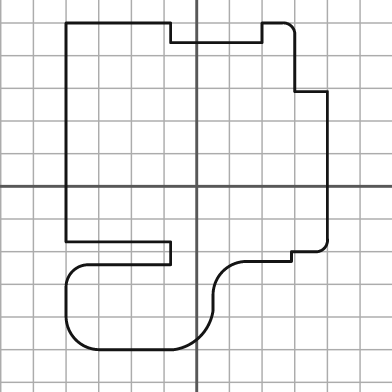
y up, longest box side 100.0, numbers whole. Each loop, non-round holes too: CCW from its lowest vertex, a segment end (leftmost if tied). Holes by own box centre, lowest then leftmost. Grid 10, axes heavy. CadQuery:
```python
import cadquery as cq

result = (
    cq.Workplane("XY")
    .moveTo(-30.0, -50.0)
    .lineTo(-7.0, -50.0)
    .threePointArc((1.0, -46.0), (5.0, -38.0))
    .lineTo(5.0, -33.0)
    .threePointArc((8.0, -26.0), (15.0, -23.0))
    .lineTo(29.0, -23.0)
    .lineTo(29.0, -20.0)
    .lineTo(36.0, -20.0)
    .threePointArc((39.0, -19.0), (40.0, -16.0))
    .lineTo(40.0, 29.0)
    .lineTo(30.0, 29.0)
    .lineTo(30.0, 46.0)
    .threePointArc((29.0, 49.0), (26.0, 50.0))
    .lineTo(20.0, 50.0)
    .lineTo(20.0, 44.0)
    .lineTo(-8.0, 44.0)
    .lineTo(-8.0, 50.0)
    .lineTo(-40.0, 50.0)
    .lineTo(-40.0, -17.0)
    .lineTo(-8.0, -17.0)
    .lineTo(-8.0, -24.0)
    .lineTo(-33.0, -24.0)
    .threePointArc((-38.0, -26.0), (-40.0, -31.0))
    .lineTo(-40.0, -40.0)
    .threePointArc((-37.0, -47.0), (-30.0, -50.0))
    .close()
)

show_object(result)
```